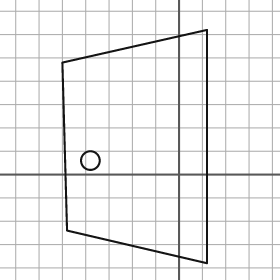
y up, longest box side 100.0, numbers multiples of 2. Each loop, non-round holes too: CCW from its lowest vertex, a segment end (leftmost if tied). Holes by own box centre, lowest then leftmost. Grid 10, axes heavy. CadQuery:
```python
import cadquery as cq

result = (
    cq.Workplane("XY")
    .moveTo(12.0, -38.0)
    .lineTo(12.0, 62.0)
    .lineTo(-50.0, 48.0)
    .lineTo(-48.0, -24.0)
    .close()
    .moveTo(-38.0, 6.0)
    .circle(4.0)
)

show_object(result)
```